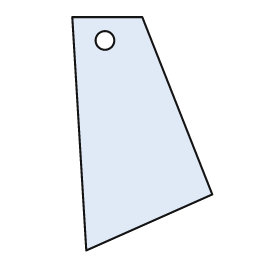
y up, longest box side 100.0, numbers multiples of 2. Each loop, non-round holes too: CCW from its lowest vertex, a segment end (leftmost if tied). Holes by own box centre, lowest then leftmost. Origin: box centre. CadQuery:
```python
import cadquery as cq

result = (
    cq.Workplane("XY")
    .moveTo(-24.0, -50.0)
    .lineTo(30.0, -26.0)
    .lineTo(0.0, 50.0)
    .lineTo(-30.0, 50.0)
    .close()
    .moveTo(-16.0, 40.0)
    .circle(4.0)
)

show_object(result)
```